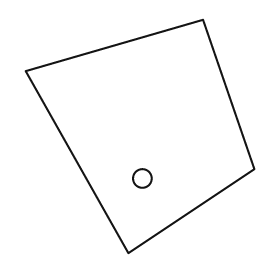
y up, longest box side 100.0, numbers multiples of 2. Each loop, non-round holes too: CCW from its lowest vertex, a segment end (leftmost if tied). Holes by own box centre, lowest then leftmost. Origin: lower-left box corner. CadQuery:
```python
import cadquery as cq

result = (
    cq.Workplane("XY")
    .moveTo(44.0, 0.0)
    .lineTo(98.0, 36.0)
    .lineTo(76.0, 100.0)
    .lineTo(0.0, 78.0)
    .close()
    .moveTo(50.0, 32.0)
    .circle(4.0)
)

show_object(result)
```